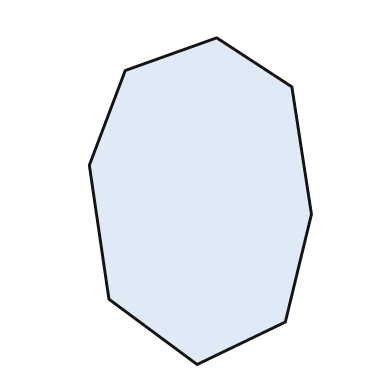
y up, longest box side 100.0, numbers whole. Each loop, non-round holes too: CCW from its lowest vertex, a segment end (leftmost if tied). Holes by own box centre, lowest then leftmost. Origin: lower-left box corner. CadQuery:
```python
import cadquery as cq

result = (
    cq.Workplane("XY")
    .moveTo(33.0, 0.0)
    .lineTo(60.0, 13.0)
    .lineTo(68.0, 46.0)
    .lineTo(62.0, 85.0)
    .lineTo(39.0, 100.0)
    .lineTo(11.0, 90.0)
    .lineTo(0.0, 61.0)
    .lineTo(6.0, 20.0)
    .close()
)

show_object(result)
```